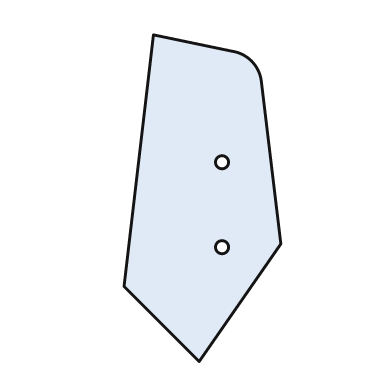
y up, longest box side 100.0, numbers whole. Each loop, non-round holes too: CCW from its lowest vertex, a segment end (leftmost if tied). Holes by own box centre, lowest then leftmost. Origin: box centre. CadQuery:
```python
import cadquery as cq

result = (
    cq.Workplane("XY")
    .moveTo(-1.0, -50.0)
    .lineTo(24.0, -14.0)
    .lineTo(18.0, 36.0)
    .threePointArc((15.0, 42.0), (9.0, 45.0))
    .lineTo(-15.0, 50.0)
    .lineTo(-24.0, -27.0)
    .close()
    .moveTo(6.0, -15.0)
    .circle(2.0)
    .moveTo(6.0, 11.0)
    .circle(2.0)
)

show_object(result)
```